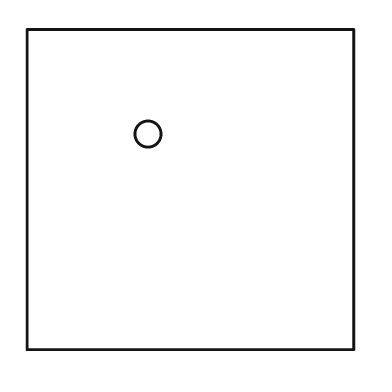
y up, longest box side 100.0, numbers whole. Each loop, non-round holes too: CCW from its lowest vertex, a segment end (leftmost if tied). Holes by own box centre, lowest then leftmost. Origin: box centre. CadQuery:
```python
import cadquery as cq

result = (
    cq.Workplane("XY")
    .moveTo(-50.0, -49.0)
    .lineTo(50.0, -49.0)
    .lineTo(50.0, 49.0)
    .lineTo(-50.0, 49.0)
    .close()
    .moveTo(-13.0, 17.0)
    .circle(4.0)
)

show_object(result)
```